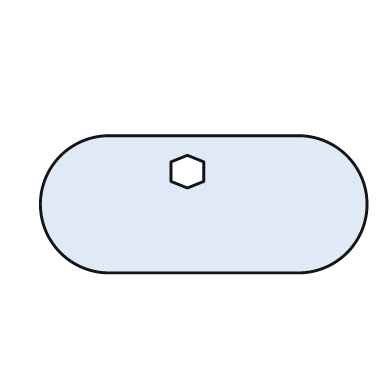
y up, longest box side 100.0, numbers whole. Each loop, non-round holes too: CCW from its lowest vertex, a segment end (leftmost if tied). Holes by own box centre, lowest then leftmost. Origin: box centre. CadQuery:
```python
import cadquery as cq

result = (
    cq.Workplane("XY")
    .moveTo(-29.0, -21.0)
    .lineTo(29.0, -21.0)
    .threePointArc((50.0, 0.0), (29.0, 21.0))
    .lineTo(-29.0, 21.0)
    .threePointArc((-50.0, 0.0), (-29.0, -21.0))
    .close()
    .moveTo(-5.0, 5.0)
    .lineTo(0.0, 7.0)
    .lineTo(0.0, 13.0)
    .lineTo(-5.0, 15.0)
    .lineTo(-10.0, 13.0)
    .lineTo(-10.0, 7.0)
    .close()
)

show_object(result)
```